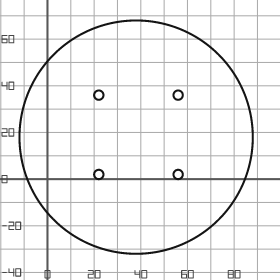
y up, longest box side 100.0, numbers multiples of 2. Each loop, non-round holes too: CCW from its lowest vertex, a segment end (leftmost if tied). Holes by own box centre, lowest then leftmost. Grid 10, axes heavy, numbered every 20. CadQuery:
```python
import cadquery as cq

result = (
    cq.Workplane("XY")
    .moveTo(38.0, 18.0)
    .circle(50.0)
    .moveTo(22.0, 2.0)
    .circle(2.0)
    .moveTo(56.0, 2.0)
    .circle(2.0)
    .moveTo(22.0, 36.0)
    .circle(2.0)
    .moveTo(56.0, 36.0)
    .circle(2.0)
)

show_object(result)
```